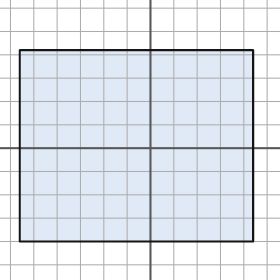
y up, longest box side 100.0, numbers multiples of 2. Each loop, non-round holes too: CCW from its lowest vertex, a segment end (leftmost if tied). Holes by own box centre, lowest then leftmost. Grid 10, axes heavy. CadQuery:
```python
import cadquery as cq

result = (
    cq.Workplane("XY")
    .moveTo(-56.0, -40.0)
    .lineTo(44.0, -40.0)
    .lineTo(44.0, 42.0)
    .lineTo(-56.0, 42.0)
    .close()
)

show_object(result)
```